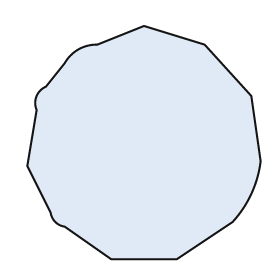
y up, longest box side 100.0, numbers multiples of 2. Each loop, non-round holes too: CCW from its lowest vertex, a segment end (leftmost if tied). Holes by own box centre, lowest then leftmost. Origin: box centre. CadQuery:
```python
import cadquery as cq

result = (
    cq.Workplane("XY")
    .moveTo(-14.0, -50.0)
    .lineTo(14.0, -50.0)
    .lineTo(38.0, -34.0)
    .threePointArc((46.0, -22.0), (50.0, -8.0))
    .lineTo(46.0, 20.0)
    .lineTo(26.0, 42.0)
    .lineTo(0.0, 50.0)
    .lineTo(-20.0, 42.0)
    .threePointArc((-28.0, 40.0), (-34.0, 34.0))
    .lineTo(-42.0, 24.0)
    .threePointArc((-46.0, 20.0), (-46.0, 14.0))
    .lineTo(-50.0, -10.0)
    .lineTo(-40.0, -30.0)
    .threePointArc((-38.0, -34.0), (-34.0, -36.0))
    .close()
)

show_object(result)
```